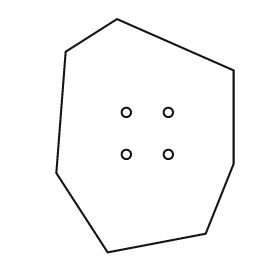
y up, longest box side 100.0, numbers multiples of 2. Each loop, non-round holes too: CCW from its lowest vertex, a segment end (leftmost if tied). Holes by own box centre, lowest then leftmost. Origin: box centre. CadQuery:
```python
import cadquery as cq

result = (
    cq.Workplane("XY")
    .moveTo(-16.0, -50.0)
    .lineTo(26.0, -42.0)
    .lineTo(38.0, -12.0)
    .lineTo(38.0, 28.0)
    .lineTo(-12.0, 50.0)
    .lineTo(-34.0, 36.0)
    .lineTo(-38.0, -16.0)
    .close()
    .moveTo(-8.0, -8.0)
    .circle(2.0)
    .moveTo(10.0, -8.0)
    .circle(2.0)
    .moveTo(-8.0, 10.0)
    .circle(2.0)
    .moveTo(10.0, 10.0)
    .circle(2.0)
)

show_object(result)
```